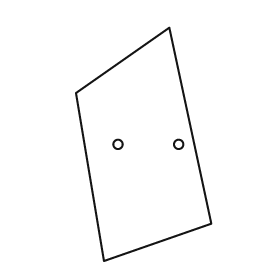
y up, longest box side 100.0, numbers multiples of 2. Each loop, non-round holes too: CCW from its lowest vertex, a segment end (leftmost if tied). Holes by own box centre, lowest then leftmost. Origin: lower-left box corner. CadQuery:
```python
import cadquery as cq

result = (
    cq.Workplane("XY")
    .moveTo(12.0, 0.0)
    .lineTo(58.0, 16.0)
    .lineTo(40.0, 100.0)
    .lineTo(0.0, 72.0)
    .close()
    .moveTo(18.0, 50.0)
    .circle(2.0)
    .moveTo(44.0, 50.0)
    .circle(2.0)
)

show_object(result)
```